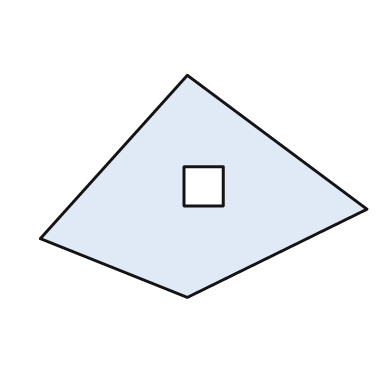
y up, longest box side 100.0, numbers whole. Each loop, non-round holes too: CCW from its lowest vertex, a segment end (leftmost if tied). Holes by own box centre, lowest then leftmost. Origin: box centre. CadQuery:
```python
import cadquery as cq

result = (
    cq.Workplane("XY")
    .moveTo(-5.0, -34.0)
    .lineTo(50.0, -7.0)
    .lineTo(-5.0, 34.0)
    .lineTo(-50.0, -16.0)
    .close()
    .moveTo(-6.0, -6.0)
    .lineTo(6.0, -6.0)
    .lineTo(6.0, 6.0)
    .lineTo(-6.0, 6.0)
    .close()
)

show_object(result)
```